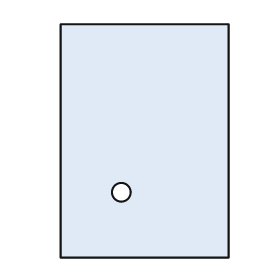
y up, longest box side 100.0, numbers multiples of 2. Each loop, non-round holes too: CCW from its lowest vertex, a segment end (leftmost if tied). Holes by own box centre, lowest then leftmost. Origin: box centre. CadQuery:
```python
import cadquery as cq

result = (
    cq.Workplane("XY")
    .moveTo(-36.0, -50.0)
    .lineTo(36.0, -50.0)
    .lineTo(36.0, 50.0)
    .lineTo(-36.0, 50.0)
    .close()
    .moveTo(-10.0, -22.0)
    .circle(4.0)
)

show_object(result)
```